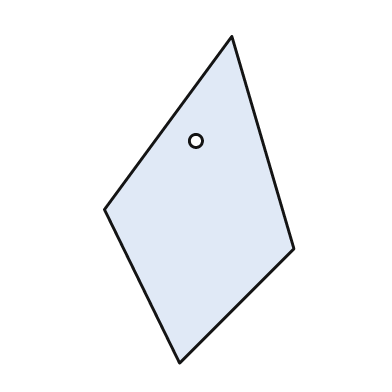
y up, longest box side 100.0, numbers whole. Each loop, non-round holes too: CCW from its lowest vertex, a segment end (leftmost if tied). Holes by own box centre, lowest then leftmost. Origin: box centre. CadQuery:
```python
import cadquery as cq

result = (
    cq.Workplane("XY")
    .moveTo(-6.0, -50.0)
    .lineTo(29.0, -15.0)
    .lineTo(10.0, 50.0)
    .lineTo(-29.0, -3.0)
    .close()
    .moveTo(-1.0, 18.0)
    .circle(2.0)
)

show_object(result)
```